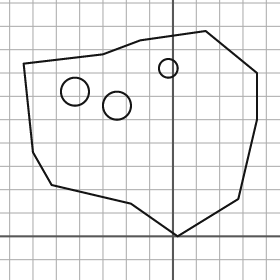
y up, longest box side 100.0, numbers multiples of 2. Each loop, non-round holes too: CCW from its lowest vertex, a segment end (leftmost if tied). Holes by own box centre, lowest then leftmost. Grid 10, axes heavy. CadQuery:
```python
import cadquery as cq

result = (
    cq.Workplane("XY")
    .moveTo(2.0, 0.0)
    .lineTo(28.0, 16.0)
    .lineTo(36.0, 50.0)
    .lineTo(36.0, 70.0)
    .lineTo(14.0, 88.0)
    .lineTo(-14.0, 84.0)
    .lineTo(-30.0, 78.0)
    .lineTo(-64.0, 74.0)
    .lineTo(-60.0, 36.0)
    .lineTo(-52.0, 22.0)
    .lineTo(-18.0, 14.0)
    .close()
    .moveTo(-24.0, 56.0)
    .circle(6.0)
    .moveTo(-42.0, 62.0)
    .circle(6.0)
    .moveTo(-2.0, 72.0)
    .circle(4.0)
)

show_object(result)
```